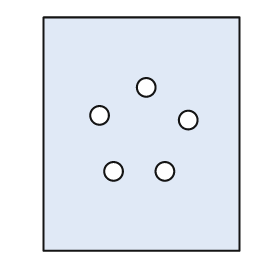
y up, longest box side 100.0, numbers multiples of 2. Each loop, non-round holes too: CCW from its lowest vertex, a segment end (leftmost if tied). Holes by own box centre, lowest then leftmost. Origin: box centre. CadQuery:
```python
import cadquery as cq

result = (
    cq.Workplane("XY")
    .moveTo(-42.0, -50.0)
    .lineTo(42.0, -50.0)
    .lineTo(42.0, 50.0)
    .lineTo(-42.0, 50.0)
    .close()
    .moveTo(-12.0, -16.0)
    .circle(4.0)
    .moveTo(10.0, -16.0)
    .circle(4.0)
    .moveTo(20.0, 6.0)
    .circle(4.0)
    .moveTo(-18.0, 8.0)
    .circle(4.0)
    .moveTo(2.0, 20.0)
    .circle(4.0)
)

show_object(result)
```